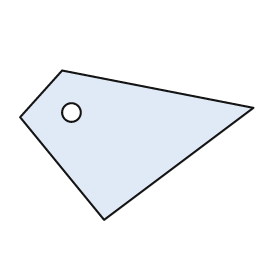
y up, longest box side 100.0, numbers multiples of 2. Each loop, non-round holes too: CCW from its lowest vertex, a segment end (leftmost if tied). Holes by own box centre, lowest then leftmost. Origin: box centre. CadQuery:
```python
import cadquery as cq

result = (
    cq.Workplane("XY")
    .moveTo(-14.0, -32.0)
    .lineTo(50.0, 16.0)
    .lineTo(-32.0, 32.0)
    .lineTo(-50.0, 12.0)
    .close()
    .moveTo(-28.0, 14.0)
    .circle(4.0)
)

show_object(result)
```